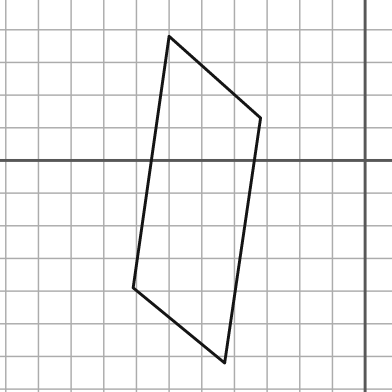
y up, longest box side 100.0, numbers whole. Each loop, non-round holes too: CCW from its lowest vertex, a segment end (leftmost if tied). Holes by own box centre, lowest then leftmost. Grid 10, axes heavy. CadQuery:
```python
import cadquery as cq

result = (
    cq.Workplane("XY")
    .moveTo(-43.0, -62.0)
    .lineTo(-32.0, 13.0)
    .lineTo(-60.0, 38.0)
    .lineTo(-71.0, -39.0)
    .close()
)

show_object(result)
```